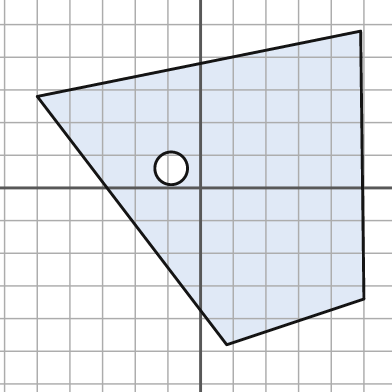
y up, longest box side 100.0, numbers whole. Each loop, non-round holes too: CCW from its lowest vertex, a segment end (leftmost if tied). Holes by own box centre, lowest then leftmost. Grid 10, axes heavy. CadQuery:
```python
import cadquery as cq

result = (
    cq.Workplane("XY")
    .moveTo(8.0, -48.0)
    .lineTo(50.0, -34.0)
    .lineTo(49.0, 48.0)
    .lineTo(-50.0, 28.0)
    .close()
    .moveTo(-9.0, 6.0)
    .circle(5.0)
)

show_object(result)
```